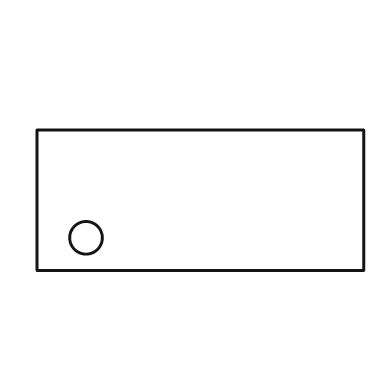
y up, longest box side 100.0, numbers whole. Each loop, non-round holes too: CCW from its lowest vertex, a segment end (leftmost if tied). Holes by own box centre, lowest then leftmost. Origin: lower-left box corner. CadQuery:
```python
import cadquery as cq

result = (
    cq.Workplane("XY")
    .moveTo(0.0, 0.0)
    .lineTo(100.0, 0.0)
    .lineTo(100.0, 43.0)
    .lineTo(0.0, 43.0)
    .close()
    .moveTo(15.0, 10.0)
    .circle(5.0)
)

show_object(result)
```